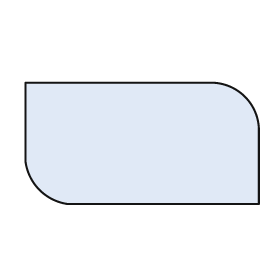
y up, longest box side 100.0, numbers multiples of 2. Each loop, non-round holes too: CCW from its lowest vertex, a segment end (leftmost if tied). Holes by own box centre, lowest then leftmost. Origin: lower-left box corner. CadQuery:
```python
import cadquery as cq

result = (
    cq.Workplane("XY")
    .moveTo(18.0, 0.0)
    .lineTo(100.0, 0.0)
    .lineTo(100.0, 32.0)
    .threePointArc((94.0, 46.0), (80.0, 52.0))
    .lineTo(0.0, 52.0)
    .lineTo(0.0, 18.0)
    .threePointArc((6.0, 6.0), (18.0, 0.0))
    .close()
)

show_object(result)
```